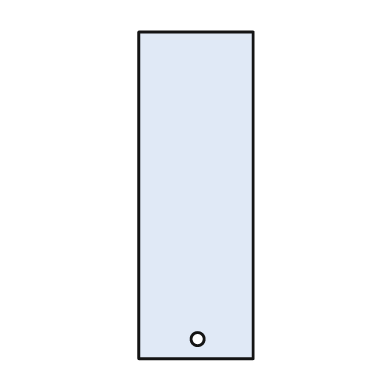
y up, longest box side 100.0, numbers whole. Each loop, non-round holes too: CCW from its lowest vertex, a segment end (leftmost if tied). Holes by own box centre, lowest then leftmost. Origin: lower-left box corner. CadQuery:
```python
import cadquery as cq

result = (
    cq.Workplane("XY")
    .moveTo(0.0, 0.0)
    .lineTo(35.0, 0.0)
    .lineTo(35.0, 100.0)
    .lineTo(0.0, 100.0)
    .close()
    .moveTo(18.0, 6.0)
    .circle(2.0)
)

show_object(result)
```